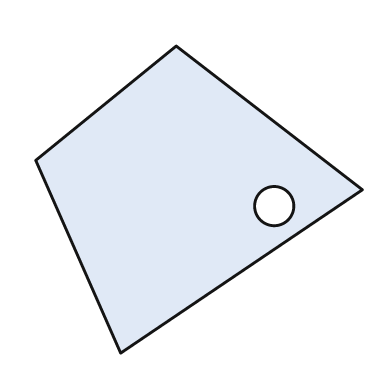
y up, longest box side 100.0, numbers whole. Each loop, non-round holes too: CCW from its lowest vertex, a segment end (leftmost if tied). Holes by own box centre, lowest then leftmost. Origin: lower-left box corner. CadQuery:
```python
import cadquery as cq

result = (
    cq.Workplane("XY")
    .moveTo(26.0, 0.0)
    .lineTo(100.0, 50.0)
    .lineTo(43.0, 94.0)
    .lineTo(0.0, 59.0)
    .close()
    .moveTo(73.0, 45.0)
    .circle(6.0)
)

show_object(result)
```